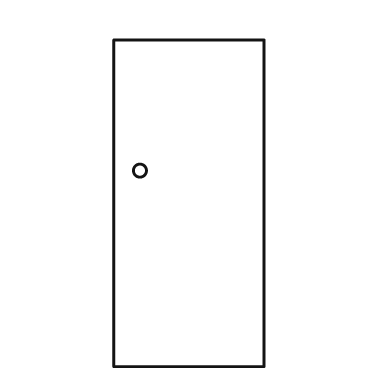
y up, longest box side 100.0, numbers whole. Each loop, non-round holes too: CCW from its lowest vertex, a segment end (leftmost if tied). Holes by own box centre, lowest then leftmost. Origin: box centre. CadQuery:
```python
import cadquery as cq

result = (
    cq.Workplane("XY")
    .moveTo(-23.0, -50.0)
    .lineTo(23.0, -50.0)
    .lineTo(23.0, 50.0)
    .lineTo(-23.0, 50.0)
    .close()
    .moveTo(-15.0, 10.0)
    .circle(2.0)
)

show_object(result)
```